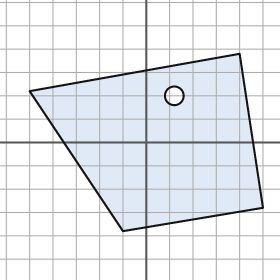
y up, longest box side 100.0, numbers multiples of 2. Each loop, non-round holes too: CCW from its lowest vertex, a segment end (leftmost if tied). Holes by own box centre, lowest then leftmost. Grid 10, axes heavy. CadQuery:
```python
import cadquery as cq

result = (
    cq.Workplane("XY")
    .moveTo(-10.0, -38.0)
    .lineTo(50.0, -28.0)
    .lineTo(40.0, 38.0)
    .lineTo(-50.0, 22.0)
    .close()
    .moveTo(12.0, 20.0)
    .circle(4.0)
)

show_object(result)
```